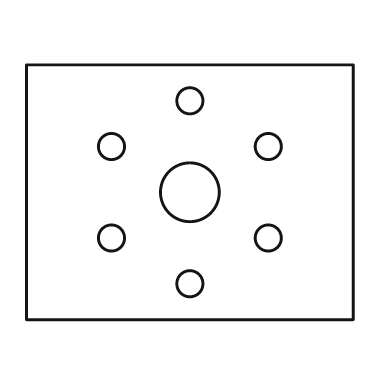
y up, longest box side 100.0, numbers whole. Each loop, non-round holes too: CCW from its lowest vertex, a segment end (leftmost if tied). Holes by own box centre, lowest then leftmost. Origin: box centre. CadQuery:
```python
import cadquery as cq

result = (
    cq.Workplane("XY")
    .moveTo(-50.0, -39.0)
    .lineTo(50.0, -39.0)
    .lineTo(50.0, 39.0)
    .lineTo(-50.0, 39.0)
    .close()
    .moveTo(0.0, -28.0)
    .circle(4.0)
    .moveTo(-24.0, -14.0)
    .circle(4.0)
    .moveTo(24.0, -14.0)
    .circle(4.0)
    .moveTo(0.0, 0.0)
    .circle(9.0)
    .moveTo(-24.0, 14.0)
    .circle(4.0)
    .moveTo(24.0, 14.0)
    .circle(4.0)
    .moveTo(0.0, 28.0)
    .circle(4.0)
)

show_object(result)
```